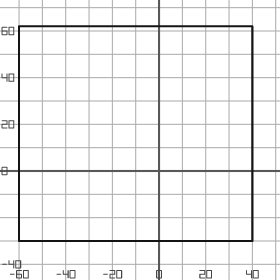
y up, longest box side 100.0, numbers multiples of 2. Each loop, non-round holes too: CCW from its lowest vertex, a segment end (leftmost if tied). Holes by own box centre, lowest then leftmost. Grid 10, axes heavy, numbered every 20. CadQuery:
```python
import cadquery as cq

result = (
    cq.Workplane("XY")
    .moveTo(-60.0, -30.0)
    .lineTo(40.0, -30.0)
    .lineTo(40.0, 62.0)
    .lineTo(-60.0, 62.0)
    .close()
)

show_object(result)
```